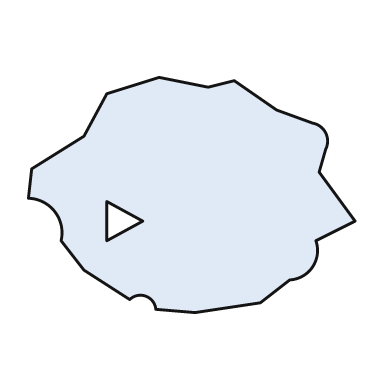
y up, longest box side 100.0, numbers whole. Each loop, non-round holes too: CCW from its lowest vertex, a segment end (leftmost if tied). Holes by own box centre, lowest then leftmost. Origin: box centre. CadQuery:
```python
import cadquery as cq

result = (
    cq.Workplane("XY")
    .moveTo(1.0, -36.0)
    .lineTo(21.0, -33.0)
    .lineTo(30.0, -26.0)
    .threePointArc((37.0, -22.0), (38.0, -14.0))
    .lineTo(50.0, -8.0)
    .lineTo(39.0, 7.0)
    .lineTo(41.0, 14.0)
    .threePointArc((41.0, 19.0), (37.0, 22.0))
    .lineTo(26.0, 26.0)
    .lineTo(13.0, 35.0)
    .lineTo(5.0, 33.0)
    .lineTo(-10.0, 36.0)
    .lineTo(-26.0, 31.0)
    .lineTo(-33.0, 18.0)
    .lineTo(-49.0, 8.0)
    .lineTo(-50.0, -1.0)
    .threePointArc((-42.0, -5.0), (-40.0, -14.0))
    .lineTo(-33.0, -23.0)
    .lineTo(-19.0, -32.0)
    .threePointArc((-14.0, -31.0), (-11.0, -35.0))
    .close()
    .moveTo(-26.0, -14.0)
    .lineTo(-15.0, -8.0)
    .lineTo(-26.0, -2.0)
    .close()
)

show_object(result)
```